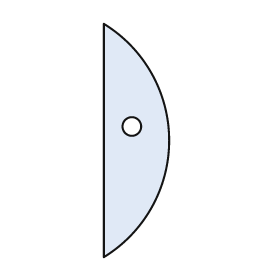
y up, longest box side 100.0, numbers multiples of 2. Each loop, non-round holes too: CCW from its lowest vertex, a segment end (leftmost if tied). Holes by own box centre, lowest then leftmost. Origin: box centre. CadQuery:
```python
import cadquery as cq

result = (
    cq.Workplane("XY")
    .moveTo(-14.0, -50.0)
    .threePointArc((14.0, 0.0), (-14.0, 50.0))
    .close()
    .moveTo(-2.0, 6.0)
    .circle(4.0)
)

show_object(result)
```